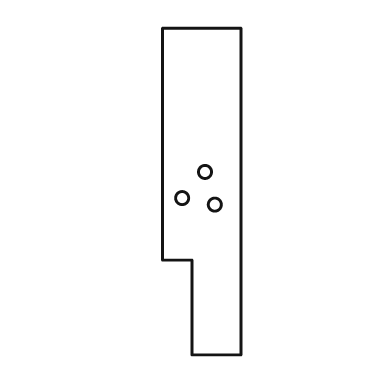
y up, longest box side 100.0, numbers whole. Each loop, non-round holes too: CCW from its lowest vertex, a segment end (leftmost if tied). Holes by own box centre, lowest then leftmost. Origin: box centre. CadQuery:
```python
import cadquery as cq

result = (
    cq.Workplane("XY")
    .moveTo(-3.0, -50.0)
    .lineTo(12.0, -50.0)
    .lineTo(12.0, 50.0)
    .lineTo(-12.0, 50.0)
    .lineTo(-12.0, -21.0)
    .lineTo(-3.0, -21.0)
    .close()
    .moveTo(4.0, -4.0)
    .circle(2.0)
    .moveTo(-6.0, -2.0)
    .circle(2.0)
    .moveTo(1.0, 6.0)
    .circle(2.0)
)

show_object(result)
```